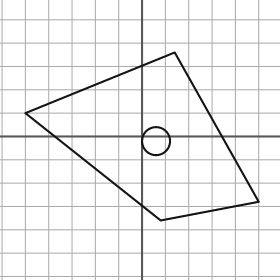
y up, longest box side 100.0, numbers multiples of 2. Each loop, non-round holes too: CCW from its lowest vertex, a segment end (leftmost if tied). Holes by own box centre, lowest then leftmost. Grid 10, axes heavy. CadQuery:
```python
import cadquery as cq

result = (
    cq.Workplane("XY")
    .moveTo(8.0, -36.0)
    .lineTo(50.0, -28.0)
    .lineTo(14.0, 36.0)
    .lineTo(-50.0, 10.0)
    .close()
    .moveTo(6.0, -2.0)
    .circle(6.0)
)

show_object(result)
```